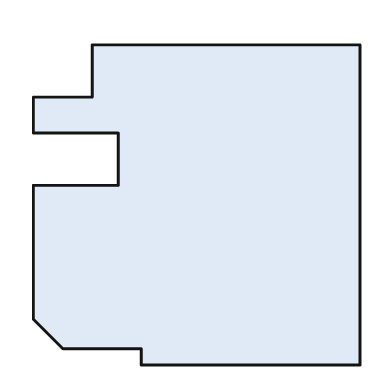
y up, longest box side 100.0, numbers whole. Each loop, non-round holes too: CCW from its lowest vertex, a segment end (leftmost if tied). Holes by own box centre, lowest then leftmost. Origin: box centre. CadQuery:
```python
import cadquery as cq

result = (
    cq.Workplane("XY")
    .moveTo(-17.0, -49.0)
    .lineTo(50.0, -49.0)
    .lineTo(50.0, 49.0)
    .lineTo(-32.0, 49.0)
    .lineTo(-32.0, 33.0)
    .lineTo(-50.0, 33.0)
    .lineTo(-50.0, 22.0)
    .lineTo(-24.0, 22.0)
    .lineTo(-24.0, 6.0)
    .lineTo(-50.0, 6.0)
    .lineTo(-50.0, -35.0)
    .lineTo(-41.0, -44.0)
    .lineTo(-17.0, -44.0)
    .close()
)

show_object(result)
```